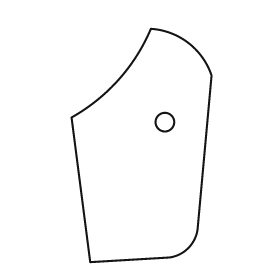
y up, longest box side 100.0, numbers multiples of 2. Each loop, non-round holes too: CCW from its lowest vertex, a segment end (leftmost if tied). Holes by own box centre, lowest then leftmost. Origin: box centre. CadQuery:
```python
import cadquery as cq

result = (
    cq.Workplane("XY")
    .moveTo(-22.0, -50.0)
    .lineTo(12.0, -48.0)
    .threePointArc((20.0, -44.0), (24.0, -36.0))
    .lineTo(30.0, 30.0)
    .threePointArc((20.0, 44.0), (4.0, 50.0))
    .threePointArc((-10.0, 28.0), (-30.0, 12.0))
    .close()
    .moveTo(10.0, 10.0)
    .circle(4.0)
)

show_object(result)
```